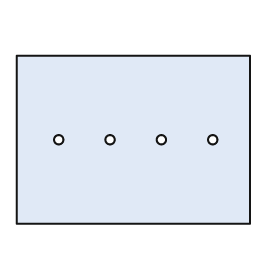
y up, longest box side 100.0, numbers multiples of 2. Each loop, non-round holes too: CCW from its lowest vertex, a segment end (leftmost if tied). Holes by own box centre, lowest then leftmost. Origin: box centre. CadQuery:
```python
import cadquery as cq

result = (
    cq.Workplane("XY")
    .moveTo(-50.0, -36.0)
    .lineTo(50.0, -36.0)
    .lineTo(50.0, 36.0)
    .lineTo(-50.0, 36.0)
    .close()
    .moveTo(-32.0, 0.0)
    .circle(2.0)
    .moveTo(-10.0, 0.0)
    .circle(2.0)
    .moveTo(12.0, 0.0)
    .circle(2.0)
    .moveTo(34.0, 0.0)
    .circle(2.0)
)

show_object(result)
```